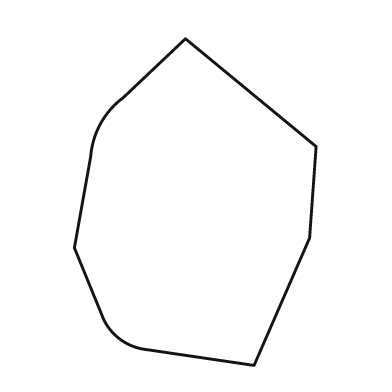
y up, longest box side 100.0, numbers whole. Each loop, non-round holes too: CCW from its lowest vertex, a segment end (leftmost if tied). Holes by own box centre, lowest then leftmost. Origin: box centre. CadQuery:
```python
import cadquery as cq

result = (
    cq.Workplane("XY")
    .moveTo(18.0, -50.0)
    .lineTo(35.0, -11.0)
    .lineTo(37.0, 17.0)
    .lineTo(-3.0, 50.0)
    .lineTo(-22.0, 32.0)
    .threePointArc((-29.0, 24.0), (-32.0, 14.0))
    .lineTo(-37.0, -14.0)
    .lineTo(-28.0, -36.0)
    .threePointArc((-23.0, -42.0), (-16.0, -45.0))
    .close()
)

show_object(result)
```